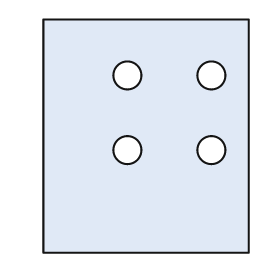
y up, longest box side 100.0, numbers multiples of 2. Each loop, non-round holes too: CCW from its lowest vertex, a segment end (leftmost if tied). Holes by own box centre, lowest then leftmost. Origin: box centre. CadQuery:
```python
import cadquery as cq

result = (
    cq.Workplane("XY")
    .moveTo(-44.0, -50.0)
    .lineTo(44.0, -50.0)
    .lineTo(44.0, 50.0)
    .lineTo(-44.0, 50.0)
    .close()
    .moveTo(-8.0, -6.0)
    .circle(6.0)
    .moveTo(28.0, -6.0)
    .circle(6.0)
    .moveTo(-8.0, 26.0)
    .circle(6.0)
    .moveTo(28.0, 26.0)
    .circle(6.0)
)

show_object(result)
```